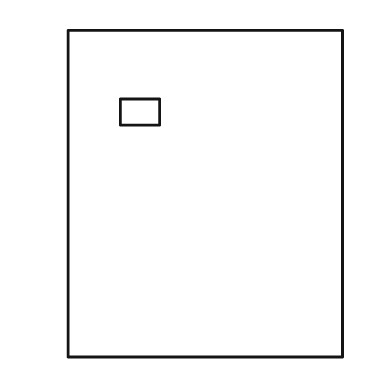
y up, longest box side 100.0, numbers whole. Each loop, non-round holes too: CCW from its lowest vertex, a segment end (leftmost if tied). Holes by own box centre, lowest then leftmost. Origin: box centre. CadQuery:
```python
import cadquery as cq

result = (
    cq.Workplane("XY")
    .moveTo(-42.0, -50.0)
    .lineTo(42.0, -50.0)
    .lineTo(42.0, 50.0)
    .lineTo(-42.0, 50.0)
    .close()
    .moveTo(-26.0, 21.0)
    .lineTo(-14.0, 21.0)
    .lineTo(-14.0, 29.0)
    .lineTo(-26.0, 29.0)
    .close()
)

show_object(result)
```